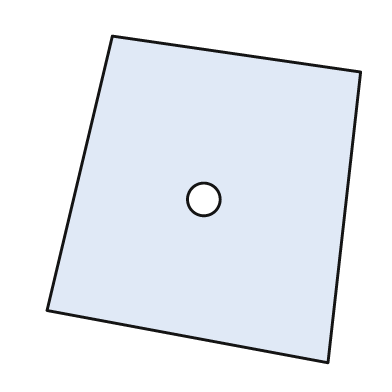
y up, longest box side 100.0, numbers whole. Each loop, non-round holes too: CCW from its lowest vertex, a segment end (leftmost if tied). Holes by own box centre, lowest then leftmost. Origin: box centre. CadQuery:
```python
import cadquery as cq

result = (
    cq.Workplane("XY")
    .moveTo(38.0, -50.0)
    .lineTo(48.0, 39.0)
    .lineTo(-28.0, 50.0)
    .lineTo(-48.0, -34.0)
    .close()
    .moveTo(0.0, 0.0)
    .circle(5.0)
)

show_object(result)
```